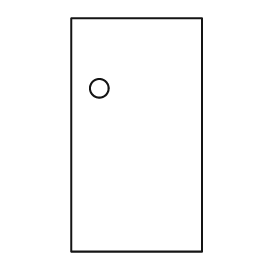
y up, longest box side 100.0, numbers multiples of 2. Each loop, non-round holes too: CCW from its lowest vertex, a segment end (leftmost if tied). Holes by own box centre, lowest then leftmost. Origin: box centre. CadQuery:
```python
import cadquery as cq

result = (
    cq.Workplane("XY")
    .moveTo(-28.0, -50.0)
    .lineTo(28.0, -50.0)
    .lineTo(28.0, 50.0)
    .lineTo(-28.0, 50.0)
    .close()
    .moveTo(-16.0, 20.0)
    .circle(4.0)
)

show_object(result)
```